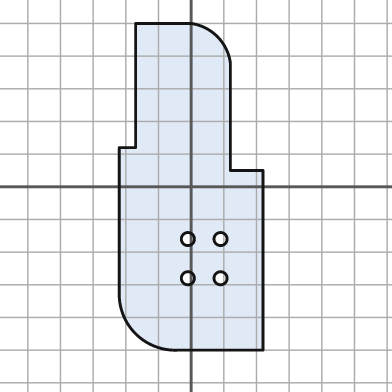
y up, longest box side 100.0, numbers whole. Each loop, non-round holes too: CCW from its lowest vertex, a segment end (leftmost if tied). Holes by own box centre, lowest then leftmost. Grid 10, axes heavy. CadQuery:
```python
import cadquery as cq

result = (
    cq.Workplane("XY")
    .moveTo(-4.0, -50.0)
    .lineTo(22.0, -50.0)
    .lineTo(22.0, 5.0)
    .lineTo(12.0, 5.0)
    .lineTo(12.0, 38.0)
    .threePointArc((8.0, 46.0), (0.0, 50.0))
    .lineTo(-17.0, 50.0)
    .lineTo(-17.0, 12.0)
    .lineTo(-22.0, 12.0)
    .lineTo(-22.0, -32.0)
    .threePointArc((-17.0, -45.0), (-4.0, -50.0))
    .close()
    .moveTo(-1.0, -28.0)
    .circle(2.0)
    .moveTo(9.0, -28.0)
    .circle(2.0)
    .moveTo(-1.0, -16.0)
    .circle(2.0)
    .moveTo(9.0, -16.0)
    .circle(2.0)
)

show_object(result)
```